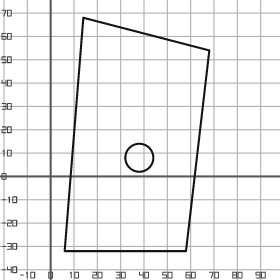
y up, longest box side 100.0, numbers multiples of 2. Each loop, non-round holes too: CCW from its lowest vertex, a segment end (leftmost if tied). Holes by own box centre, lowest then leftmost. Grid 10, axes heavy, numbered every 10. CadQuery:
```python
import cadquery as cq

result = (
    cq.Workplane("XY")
    .moveTo(6.0, -32.0)
    .lineTo(58.0, -32.0)
    .lineTo(68.0, 54.0)
    .lineTo(14.0, 68.0)
    .close()
    .moveTo(38.0, 8.0)
    .circle(6.0)
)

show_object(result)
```